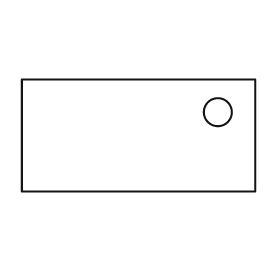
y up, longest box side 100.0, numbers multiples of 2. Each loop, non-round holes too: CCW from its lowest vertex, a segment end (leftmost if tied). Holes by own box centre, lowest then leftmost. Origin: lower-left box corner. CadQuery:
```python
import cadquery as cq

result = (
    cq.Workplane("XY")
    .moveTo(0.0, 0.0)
    .lineTo(100.0, 0.0)
    .lineTo(100.0, 48.0)
    .lineTo(0.0, 48.0)
    .close()
    .moveTo(84.0, 34.0)
    .circle(6.0)
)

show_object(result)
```